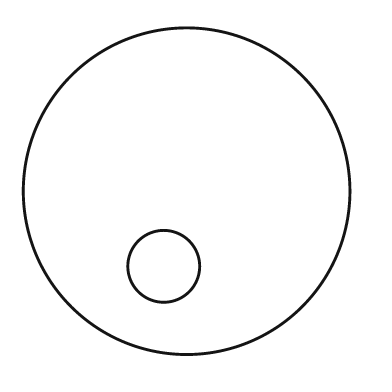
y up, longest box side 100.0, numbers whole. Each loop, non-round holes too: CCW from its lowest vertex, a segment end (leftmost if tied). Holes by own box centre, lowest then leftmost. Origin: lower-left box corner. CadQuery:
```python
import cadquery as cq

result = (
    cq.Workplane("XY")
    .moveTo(50.0, 50.0)
    .circle(50.0)
    .moveTo(43.0, 27.0)
    .circle(11.0)
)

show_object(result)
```